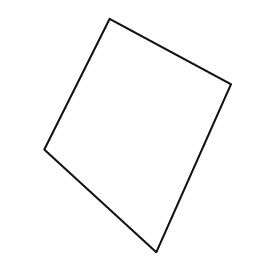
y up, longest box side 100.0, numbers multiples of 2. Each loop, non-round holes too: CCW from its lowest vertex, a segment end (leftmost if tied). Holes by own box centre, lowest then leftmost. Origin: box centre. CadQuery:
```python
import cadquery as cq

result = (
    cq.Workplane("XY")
    .moveTo(8.0, -50.0)
    .lineTo(40.0, 22.0)
    .lineTo(-12.0, 50.0)
    .lineTo(-40.0, -6.0)
    .close()
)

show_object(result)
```